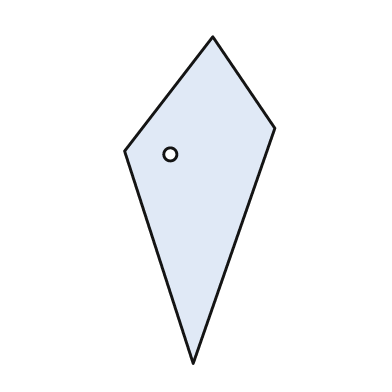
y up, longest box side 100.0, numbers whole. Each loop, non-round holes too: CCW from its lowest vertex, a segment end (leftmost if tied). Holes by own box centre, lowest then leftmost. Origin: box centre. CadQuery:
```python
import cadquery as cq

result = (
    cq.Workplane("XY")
    .moveTo(-2.0, -50.0)
    .lineTo(23.0, 22.0)
    .lineTo(4.0, 50.0)
    .lineTo(-23.0, 15.0)
    .close()
    .moveTo(-9.0, 14.0)
    .circle(2.0)
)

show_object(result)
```